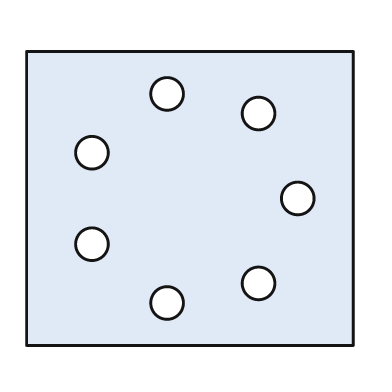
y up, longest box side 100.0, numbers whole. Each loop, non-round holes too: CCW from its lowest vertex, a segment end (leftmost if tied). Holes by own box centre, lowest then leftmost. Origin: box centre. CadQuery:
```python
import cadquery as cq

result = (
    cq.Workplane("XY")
    .moveTo(-50.0, -45.0)
    .lineTo(50.0, -45.0)
    .lineTo(50.0, 45.0)
    .lineTo(-50.0, 45.0)
    .close()
    .moveTo(-7.0, -32.0)
    .circle(5.0)
    .moveTo(21.0, -26.0)
    .circle(5.0)
    .moveTo(-30.0, -14.0)
    .circle(5.0)
    .moveTo(33.0, 0.0)
    .circle(5.0)
    .moveTo(-30.0, 14.0)
    .circle(5.0)
    .moveTo(21.0, 26.0)
    .circle(5.0)
    .moveTo(-7.0, 32.0)
    .circle(5.0)
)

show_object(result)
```